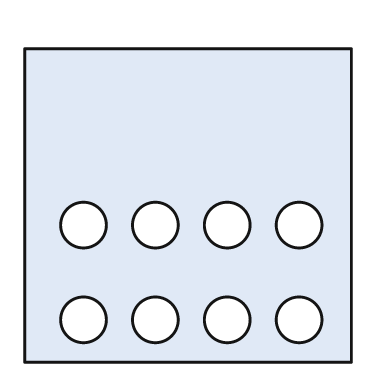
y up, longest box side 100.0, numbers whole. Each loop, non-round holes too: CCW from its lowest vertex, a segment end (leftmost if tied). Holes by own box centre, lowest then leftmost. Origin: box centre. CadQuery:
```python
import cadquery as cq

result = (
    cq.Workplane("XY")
    .moveTo(-50.0, -48.0)
    .lineTo(50.0, -48.0)
    .lineTo(50.0, 48.0)
    .lineTo(-50.0, 48.0)
    .close()
    .moveTo(-32.0, -35.0)
    .circle(7.0)
    .moveTo(-10.0, -35.0)
    .circle(7.0)
    .moveTo(12.0, -35.0)
    .circle(7.0)
    .moveTo(34.0, -35.0)
    .circle(7.0)
    .moveTo(-32.0, -6.0)
    .circle(7.0)
    .moveTo(-10.0, -6.0)
    .circle(7.0)
    .moveTo(12.0, -6.0)
    .circle(7.0)
    .moveTo(34.0, -6.0)
    .circle(7.0)
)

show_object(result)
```